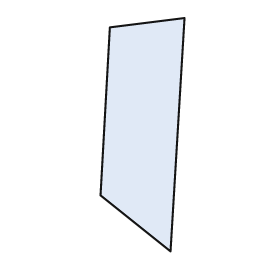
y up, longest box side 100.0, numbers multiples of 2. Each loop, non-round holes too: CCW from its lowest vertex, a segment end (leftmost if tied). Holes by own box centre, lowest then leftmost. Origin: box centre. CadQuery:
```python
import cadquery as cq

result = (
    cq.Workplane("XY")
    .moveTo(12.0, -50.0)
    .lineTo(18.0, 50.0)
    .lineTo(-14.0, 46.0)
    .lineTo(-18.0, -26.0)
    .close()
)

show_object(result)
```